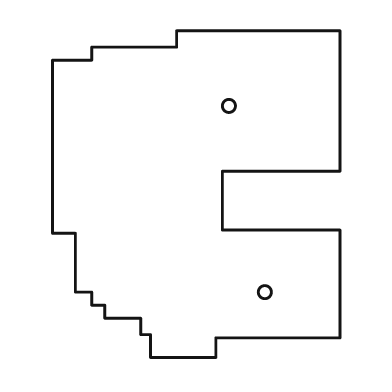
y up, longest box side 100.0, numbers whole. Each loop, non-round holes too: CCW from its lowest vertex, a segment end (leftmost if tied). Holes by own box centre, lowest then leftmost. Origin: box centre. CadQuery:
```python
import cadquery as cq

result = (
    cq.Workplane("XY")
    .moveTo(-14.0, -50.0)
    .lineTo(6.0, -50.0)
    .lineTo(6.0, -44.0)
    .lineTo(44.0, -44.0)
    .lineTo(44.0, -11.0)
    .lineTo(8.0, -11.0)
    .lineTo(8.0, 7.0)
    .lineTo(44.0, 7.0)
    .lineTo(44.0, 50.0)
    .lineTo(-6.0, 50.0)
    .lineTo(-6.0, 45.0)
    .lineTo(-32.0, 45.0)
    .lineTo(-32.0, 41.0)
    .lineTo(-44.0, 41.0)
    .lineTo(-44.0, -12.0)
    .lineTo(-37.0, -12.0)
    .lineTo(-37.0, -30.0)
    .lineTo(-32.0, -30.0)
    .lineTo(-32.0, -34.0)
    .lineTo(-28.0, -34.0)
    .lineTo(-28.0, -38.0)
    .lineTo(-17.0, -38.0)
    .lineTo(-17.0, -43.0)
    .lineTo(-14.0, -43.0)
    .close()
    .moveTo(21.0, -30.0)
    .circle(2.0)
    .moveTo(10.0, 27.0)
    .circle(2.0)
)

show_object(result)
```